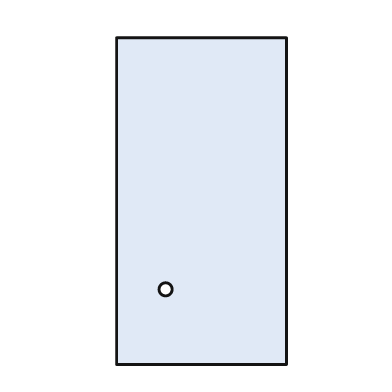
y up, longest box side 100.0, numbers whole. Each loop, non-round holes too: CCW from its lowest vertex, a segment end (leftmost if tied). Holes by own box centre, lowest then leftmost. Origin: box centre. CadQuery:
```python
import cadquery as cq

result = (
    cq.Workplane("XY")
    .moveTo(-26.0, -50.0)
    .lineTo(26.0, -50.0)
    .lineTo(26.0, 50.0)
    .lineTo(-26.0, 50.0)
    .close()
    .moveTo(-11.0, -27.0)
    .circle(2.0)
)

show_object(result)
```